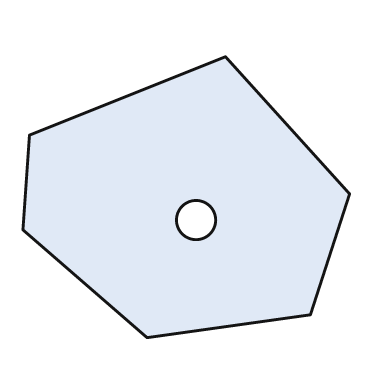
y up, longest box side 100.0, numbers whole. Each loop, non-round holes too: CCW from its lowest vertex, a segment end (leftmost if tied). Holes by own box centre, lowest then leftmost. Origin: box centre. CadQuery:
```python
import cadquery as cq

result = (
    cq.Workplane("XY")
    .moveTo(-12.0, -43.0)
    .lineTo(38.0, -36.0)
    .lineTo(50.0, 1.0)
    .lineTo(12.0, 43.0)
    .lineTo(-48.0, 19.0)
    .lineTo(-50.0, -10.0)
    .close()
    .moveTo(3.0, -7.0)
    .circle(6.0)
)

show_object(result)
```